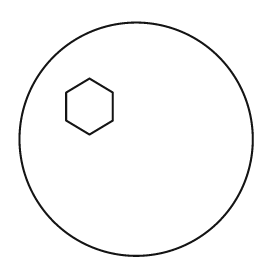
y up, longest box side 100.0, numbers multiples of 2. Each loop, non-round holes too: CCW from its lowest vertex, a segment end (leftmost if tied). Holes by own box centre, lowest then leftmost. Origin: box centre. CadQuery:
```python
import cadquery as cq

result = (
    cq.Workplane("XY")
    .moveTo(0.0, 0.0)
    .circle(50.0)
    .moveTo(-20.0, 2.0)
    .lineTo(-10.0, 8.0)
    .lineTo(-10.0, 20.0)
    .lineTo(-20.0, 26.0)
    .lineTo(-30.0, 20.0)
    .lineTo(-30.0, 8.0)
    .close()
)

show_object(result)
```